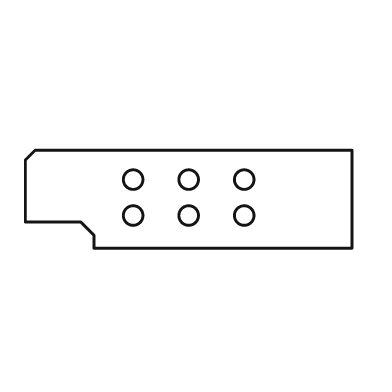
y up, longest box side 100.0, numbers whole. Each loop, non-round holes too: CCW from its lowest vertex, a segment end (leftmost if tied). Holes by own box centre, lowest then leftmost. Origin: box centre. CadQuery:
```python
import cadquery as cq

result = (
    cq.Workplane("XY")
    .moveTo(-29.0, -15.0)
    .lineTo(50.0, -15.0)
    .lineTo(50.0, 15.0)
    .lineTo(-47.0, 15.0)
    .lineTo(-50.0, 12.0)
    .lineTo(-50.0, -7.0)
    .lineTo(-33.0, -7.0)
    .lineTo(-29.0, -11.0)
    .close()
    .moveTo(-17.0, -5.0)
    .circle(3.0)
    .moveTo(0.0, -5.0)
    .circle(3.0)
    .moveTo(17.0, -5.0)
    .circle(3.0)
    .moveTo(-17.0, 6.0)
    .circle(3.0)
    .moveTo(0.0, 6.0)
    .circle(3.0)
    .moveTo(17.0, 6.0)
    .circle(3.0)
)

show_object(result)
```